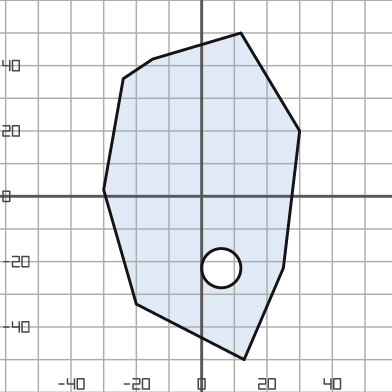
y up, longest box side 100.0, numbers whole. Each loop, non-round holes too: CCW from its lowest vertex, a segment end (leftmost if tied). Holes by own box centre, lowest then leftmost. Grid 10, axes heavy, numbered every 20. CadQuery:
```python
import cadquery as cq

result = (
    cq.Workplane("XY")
    .moveTo(13.0, -50.0)
    .lineTo(25.0, -22.0)
    .lineTo(30.0, 20.0)
    .lineTo(12.0, 50.0)
    .lineTo(-15.0, 42.0)
    .lineTo(-24.0, 36.0)
    .lineTo(-30.0, 2.0)
    .lineTo(-20.0, -33.0)
    .close()
    .moveTo(6.0, -22.0)
    .circle(6.0)
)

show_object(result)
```